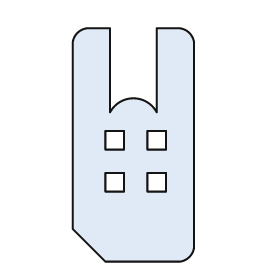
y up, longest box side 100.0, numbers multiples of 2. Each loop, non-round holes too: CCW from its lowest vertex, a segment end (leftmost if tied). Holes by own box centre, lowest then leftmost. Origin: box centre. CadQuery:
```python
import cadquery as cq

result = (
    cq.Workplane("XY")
    .moveTo(-12.0, -50.0)
    .lineTo(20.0, -50.0)
    .threePointArc((24.0, -48.0), (26.0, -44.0))
    .lineTo(26.0, 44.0)
    .threePointArc((24.0, 48.0), (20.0, 50.0))
    .lineTo(10.0, 50.0)
    .lineTo(10.0, 14.0)
    .threePointArc((0.0, 20.0), (-10.0, 14.0))
    .lineTo(-10.0, 50.0)
    .lineTo(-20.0, 50.0)
    .threePointArc((-24.0, 48.0), (-26.0, 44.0))
    .lineTo(-26.0, -36.0)
    .close()
    .moveTo(-12.0, -20.0)
    .lineTo(-4.0, -20.0)
    .lineTo(-4.0, -12.0)
    .lineTo(-12.0, -12.0)
    .close()
    .moveTo(6.0, -20.0)
    .lineTo(14.0, -20.0)
    .lineTo(14.0, -12.0)
    .lineTo(6.0, -12.0)
    .close()
    .moveTo(-12.0, -2.0)
    .lineTo(-4.0, -2.0)
    .lineTo(-4.0, 6.0)
    .lineTo(-12.0, 6.0)
    .close()
    .moveTo(6.0, -2.0)
    .lineTo(14.0, -2.0)
    .lineTo(14.0, 6.0)
    .lineTo(6.0, 6.0)
    .close()
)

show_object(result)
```